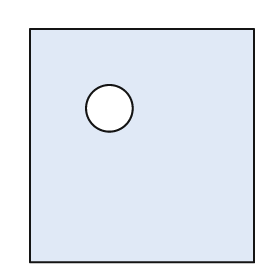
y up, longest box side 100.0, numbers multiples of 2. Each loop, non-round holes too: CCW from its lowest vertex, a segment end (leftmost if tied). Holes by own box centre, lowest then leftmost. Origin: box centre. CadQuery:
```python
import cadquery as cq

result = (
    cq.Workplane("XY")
    .moveTo(-48.0, -50.0)
    .lineTo(48.0, -50.0)
    .lineTo(48.0, 50.0)
    .lineTo(-48.0, 50.0)
    .close()
    .moveTo(-14.0, 16.0)
    .circle(10.0)
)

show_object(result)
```